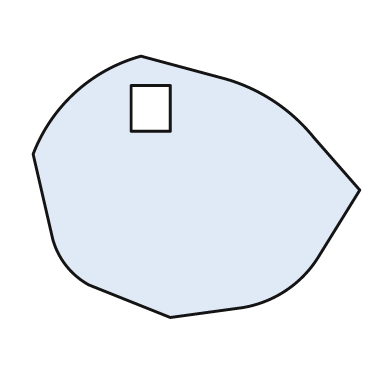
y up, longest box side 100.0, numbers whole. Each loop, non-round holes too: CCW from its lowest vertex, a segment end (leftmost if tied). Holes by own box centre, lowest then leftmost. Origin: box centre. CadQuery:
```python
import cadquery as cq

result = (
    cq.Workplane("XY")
    .moveTo(-8.0, -40.0)
    .lineTo(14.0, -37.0)
    .threePointArc((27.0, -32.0), (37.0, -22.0))
    .lineTo(50.0, -1.0)
    .lineTo(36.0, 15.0)
    .threePointArc((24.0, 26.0), (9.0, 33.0))
    .lineTo(-17.0, 40.0)
    .threePointArc((-37.0, 29.0), (-50.0, 10.0))
    .lineTo(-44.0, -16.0)
    .threePointArc((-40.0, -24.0), (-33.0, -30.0))
    .close()
    .moveTo(-20.0, 17.0)
    .lineTo(-8.0, 17.0)
    .lineTo(-8.0, 31.0)
    .lineTo(-20.0, 31.0)
    .close()
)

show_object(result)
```